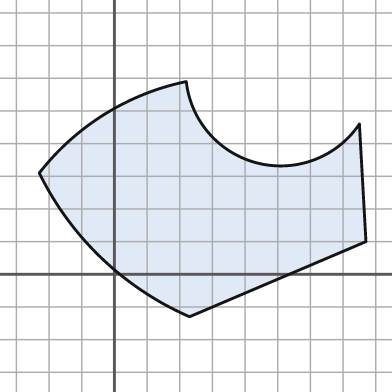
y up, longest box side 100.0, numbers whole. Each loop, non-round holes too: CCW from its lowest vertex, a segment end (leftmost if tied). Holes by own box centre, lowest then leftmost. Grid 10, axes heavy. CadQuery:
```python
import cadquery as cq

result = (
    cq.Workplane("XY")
    .moveTo(23.0, -13.0)
    .lineTo(77.0, 10.0)
    .lineTo(75.0, 46.0)
    .threePointArc((44.0, 34.0), (22.0, 59.0))
    .threePointArc((-3.0, 49.0), (-23.0, 31.0))
    .threePointArc((-4.0, 5.0), (23.0, -13.0))
    .close()
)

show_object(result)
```